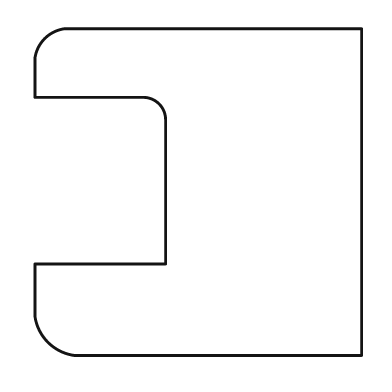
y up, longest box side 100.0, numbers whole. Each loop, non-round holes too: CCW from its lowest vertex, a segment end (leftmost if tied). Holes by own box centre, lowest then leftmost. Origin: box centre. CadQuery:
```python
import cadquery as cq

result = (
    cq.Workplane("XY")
    .moveTo(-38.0, -50.0)
    .lineTo(50.0, -50.0)
    .lineTo(50.0, 50.0)
    .lineTo(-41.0, 50.0)
    .threePointArc((-47.0, 47.0), (-50.0, 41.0))
    .lineTo(-50.0, 29.0)
    .lineTo(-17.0, 29.0)
    .threePointArc((-12.0, 27.0), (-10.0, 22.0))
    .lineTo(-10.0, -22.0)
    .lineTo(-50.0, -22.0)
    .lineTo(-50.0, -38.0)
    .threePointArc((-46.0, -46.0), (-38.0, -50.0))
    .close()
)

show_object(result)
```